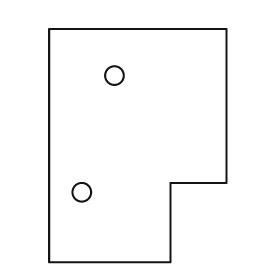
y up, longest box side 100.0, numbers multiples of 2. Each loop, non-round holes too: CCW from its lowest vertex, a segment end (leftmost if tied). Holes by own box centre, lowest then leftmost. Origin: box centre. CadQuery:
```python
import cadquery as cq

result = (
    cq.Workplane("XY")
    .moveTo(-38.0, -50.0)
    .lineTo(14.0, -50.0)
    .lineTo(14.0, -16.0)
    .lineTo(38.0, -16.0)
    .lineTo(38.0, 50.0)
    .lineTo(-38.0, 50.0)
    .close()
    .moveTo(-24.0, -20.0)
    .circle(4.0)
    .moveTo(-10.0, 30.0)
    .circle(4.0)
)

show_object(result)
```